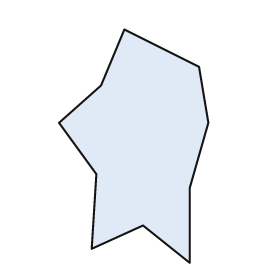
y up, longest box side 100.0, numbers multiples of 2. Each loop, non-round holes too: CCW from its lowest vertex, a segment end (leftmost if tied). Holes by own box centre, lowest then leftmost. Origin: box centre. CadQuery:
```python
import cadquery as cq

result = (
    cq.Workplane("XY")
    .moveTo(24.0, -50.0)
    .lineTo(24.0, -18.0)
    .lineTo(32.0, 10.0)
    .lineTo(28.0, 34.0)
    .lineTo(-4.0, 50.0)
    .lineTo(-14.0, 26.0)
    .lineTo(-32.0, 10.0)
    .lineTo(-16.0, -12.0)
    .lineTo(-18.0, -44.0)
    .lineTo(4.0, -34.0)
    .close()
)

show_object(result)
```